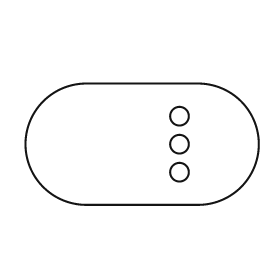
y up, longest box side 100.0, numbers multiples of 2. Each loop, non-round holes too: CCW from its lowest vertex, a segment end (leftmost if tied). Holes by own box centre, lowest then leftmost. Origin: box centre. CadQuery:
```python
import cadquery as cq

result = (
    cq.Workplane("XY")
    .moveTo(-24.0, -26.0)
    .lineTo(24.0, -26.0)
    .threePointArc((50.0, 0.0), (24.0, 26.0))
    .lineTo(-24.0, 26.0)
    .threePointArc((-50.0, 0.0), (-24.0, -26.0))
    .close()
    .moveTo(16.0, -12.0)
    .circle(4.0)
    .moveTo(16.0, 0.0)
    .circle(4.0)
    .moveTo(16.0, 12.0)
    .circle(4.0)
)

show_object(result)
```